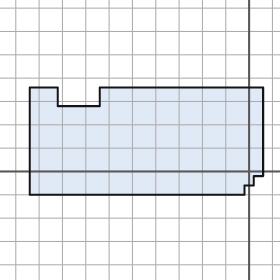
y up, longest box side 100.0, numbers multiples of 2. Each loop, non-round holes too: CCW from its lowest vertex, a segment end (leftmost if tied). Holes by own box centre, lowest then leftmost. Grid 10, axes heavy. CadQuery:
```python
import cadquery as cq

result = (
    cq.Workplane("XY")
    .moveTo(-94.0, -10.0)
    .lineTo(-2.0, -10.0)
    .lineTo(-2.0, -6.0)
    .lineTo(2.0, -6.0)
    .lineTo(2.0, -2.0)
    .lineTo(6.0, -2.0)
    .lineTo(6.0, 36.0)
    .lineTo(-64.0, 36.0)
    .lineTo(-64.0, 28.0)
    .lineTo(-82.0, 28.0)
    .lineTo(-82.0, 36.0)
    .lineTo(-94.0, 36.0)
    .close()
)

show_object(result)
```